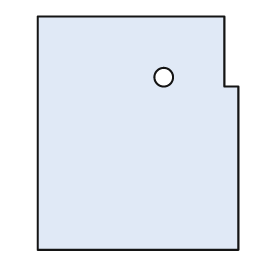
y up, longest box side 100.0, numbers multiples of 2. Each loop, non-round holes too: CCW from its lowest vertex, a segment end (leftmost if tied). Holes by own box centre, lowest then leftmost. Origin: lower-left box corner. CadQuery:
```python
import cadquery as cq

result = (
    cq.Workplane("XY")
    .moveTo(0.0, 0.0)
    .lineTo(86.0, 0.0)
    .lineTo(86.0, 70.0)
    .lineTo(80.0, 70.0)
    .lineTo(80.0, 100.0)
    .lineTo(0.0, 100.0)
    .close()
    .moveTo(54.0, 74.0)
    .circle(4.0)
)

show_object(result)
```